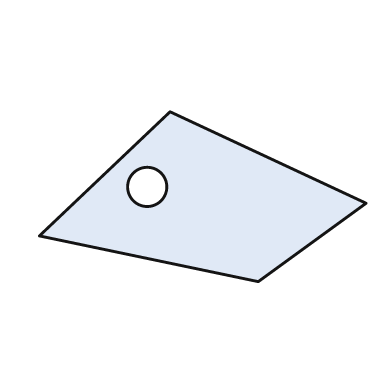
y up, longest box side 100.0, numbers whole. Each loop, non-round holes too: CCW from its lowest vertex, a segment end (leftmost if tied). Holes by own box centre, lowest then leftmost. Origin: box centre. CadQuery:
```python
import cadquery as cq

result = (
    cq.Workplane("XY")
    .moveTo(17.0, -26.0)
    .lineTo(50.0, -2.0)
    .lineTo(-10.0, 26.0)
    .lineTo(-50.0, -12.0)
    .close()
    .moveTo(-17.0, 3.0)
    .circle(6.0)
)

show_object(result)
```